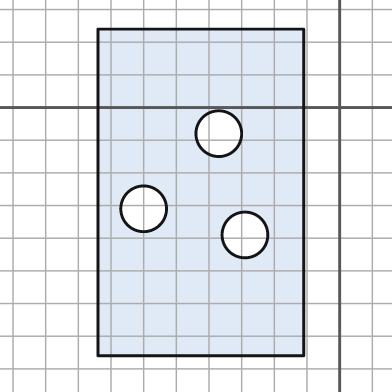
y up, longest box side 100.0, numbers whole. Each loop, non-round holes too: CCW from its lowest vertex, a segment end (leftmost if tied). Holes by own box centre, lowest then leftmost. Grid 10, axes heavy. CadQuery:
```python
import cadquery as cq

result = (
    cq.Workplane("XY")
    .moveTo(-74.0, -76.0)
    .lineTo(-11.0, -76.0)
    .lineTo(-11.0, 24.0)
    .lineTo(-74.0, 24.0)
    .close()
    .moveTo(-29.0, -39.0)
    .circle(7.0)
    .moveTo(-60.0, -31.0)
    .circle(7.0)
    .moveTo(-37.0, -8.0)
    .circle(7.0)
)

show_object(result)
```